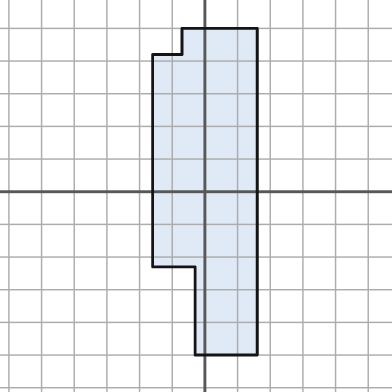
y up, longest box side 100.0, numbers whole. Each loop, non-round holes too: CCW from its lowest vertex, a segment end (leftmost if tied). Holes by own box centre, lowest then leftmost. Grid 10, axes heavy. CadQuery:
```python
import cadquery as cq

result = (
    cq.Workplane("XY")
    .moveTo(-3.0, -50.0)
    .lineTo(16.0, -50.0)
    .lineTo(16.0, 50.0)
    .lineTo(-7.0, 50.0)
    .lineTo(-7.0, 42.0)
    .lineTo(-16.0, 42.0)
    .lineTo(-16.0, -23.0)
    .lineTo(-3.0, -23.0)
    .close()
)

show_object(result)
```